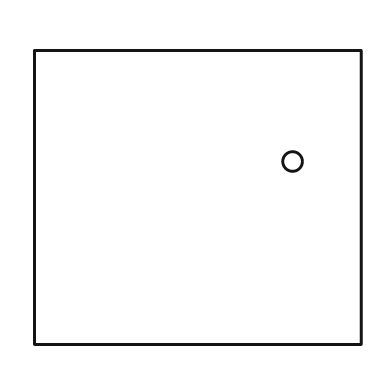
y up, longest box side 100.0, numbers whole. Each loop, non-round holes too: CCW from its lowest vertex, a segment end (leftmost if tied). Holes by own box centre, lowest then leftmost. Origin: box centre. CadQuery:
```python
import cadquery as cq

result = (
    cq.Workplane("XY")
    .moveTo(-50.0, -45.0)
    .lineTo(50.0, -45.0)
    .lineTo(50.0, 45.0)
    .lineTo(-50.0, 45.0)
    .close()
    .moveTo(29.0, 11.0)
    .circle(3.0)
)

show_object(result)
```